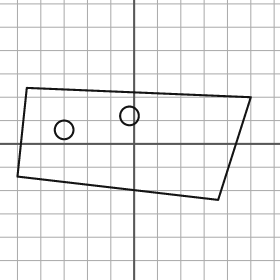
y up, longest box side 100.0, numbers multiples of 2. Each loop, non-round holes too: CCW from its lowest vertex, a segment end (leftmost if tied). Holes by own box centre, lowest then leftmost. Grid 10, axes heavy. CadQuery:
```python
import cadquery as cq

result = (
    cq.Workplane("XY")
    .moveTo(36.0, -24.0)
    .lineTo(50.0, 20.0)
    .lineTo(-46.0, 24.0)
    .lineTo(-50.0, -14.0)
    .close()
    .moveTo(-30.0, 6.0)
    .circle(4.0)
    .moveTo(-2.0, 12.0)
    .circle(4.0)
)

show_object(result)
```